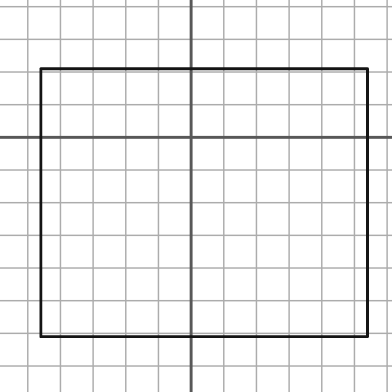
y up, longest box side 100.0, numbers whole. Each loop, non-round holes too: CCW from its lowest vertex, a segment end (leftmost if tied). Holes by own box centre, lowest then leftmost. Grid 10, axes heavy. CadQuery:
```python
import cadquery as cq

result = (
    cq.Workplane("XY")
    .moveTo(-46.0, -61.0)
    .lineTo(54.0, -61.0)
    .lineTo(54.0, 21.0)
    .lineTo(-46.0, 21.0)
    .close()
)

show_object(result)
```